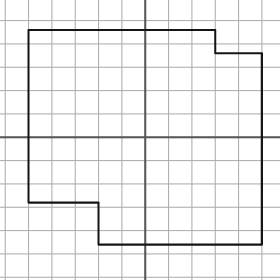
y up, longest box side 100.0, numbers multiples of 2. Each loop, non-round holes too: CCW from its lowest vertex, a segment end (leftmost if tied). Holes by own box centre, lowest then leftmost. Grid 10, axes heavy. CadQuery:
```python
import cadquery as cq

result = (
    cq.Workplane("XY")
    .moveTo(-20.0, -46.0)
    .lineTo(50.0, -46.0)
    .lineTo(50.0, 36.0)
    .lineTo(30.0, 36.0)
    .lineTo(30.0, 46.0)
    .lineTo(-50.0, 46.0)
    .lineTo(-50.0, -28.0)
    .lineTo(-20.0, -28.0)
    .close()
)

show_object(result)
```